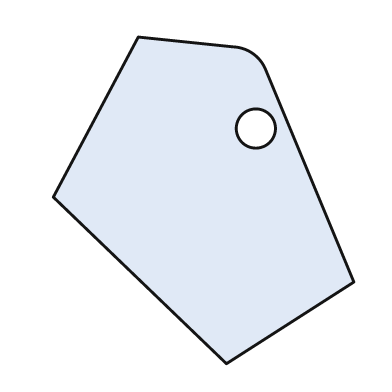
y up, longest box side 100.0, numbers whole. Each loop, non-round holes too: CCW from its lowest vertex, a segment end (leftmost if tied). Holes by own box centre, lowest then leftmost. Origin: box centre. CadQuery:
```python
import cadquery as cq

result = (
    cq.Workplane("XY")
    .moveTo(7.0, -50.0)
    .lineTo(46.0, -25.0)
    .lineTo(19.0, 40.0)
    .threePointArc((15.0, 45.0), (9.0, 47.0))
    .lineTo(-20.0, 50.0)
    .lineTo(-46.0, 1.0)
    .close()
    .moveTo(16.0, 22.0)
    .circle(6.0)
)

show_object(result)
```